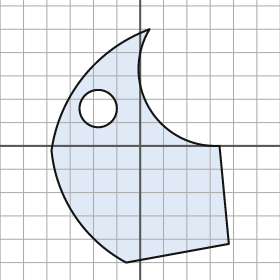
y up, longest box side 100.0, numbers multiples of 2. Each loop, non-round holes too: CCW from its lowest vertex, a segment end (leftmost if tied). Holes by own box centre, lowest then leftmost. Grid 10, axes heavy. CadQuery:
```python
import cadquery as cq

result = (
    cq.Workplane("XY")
    .moveTo(-6.0, -50.0)
    .lineTo(38.0, -42.0)
    .lineTo(34.0, 0.0)
    .threePointArc((4.0, 16.0), (4.0, 50.0))
    .threePointArc((-24.0, 30.0), (-38.0, -2.0))
    .threePointArc((-28.0, -30.0), (-6.0, -50.0))
    .close()
    .moveTo(-18.0, 16.0)
    .circle(8.0)
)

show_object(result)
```